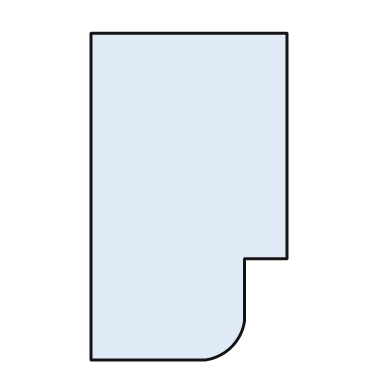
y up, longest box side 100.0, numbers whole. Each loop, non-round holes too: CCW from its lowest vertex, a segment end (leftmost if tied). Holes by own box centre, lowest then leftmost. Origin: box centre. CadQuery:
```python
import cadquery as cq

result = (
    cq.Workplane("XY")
    .moveTo(-30.0, -50.0)
    .lineTo(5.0, -50.0)
    .threePointArc((13.0, -46.0), (17.0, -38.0))
    .lineTo(17.0, -19.0)
    .lineTo(30.0, -19.0)
    .lineTo(30.0, 50.0)
    .lineTo(-30.0, 50.0)
    .close()
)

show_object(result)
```